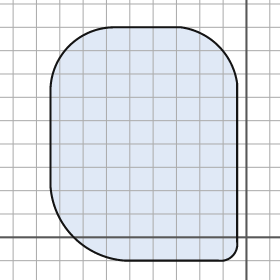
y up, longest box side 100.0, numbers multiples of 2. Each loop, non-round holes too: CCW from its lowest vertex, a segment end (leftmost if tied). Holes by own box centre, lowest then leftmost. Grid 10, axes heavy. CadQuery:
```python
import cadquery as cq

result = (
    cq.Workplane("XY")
    .moveTo(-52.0, -10.0)
    .lineTo(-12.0, -10.0)
    .threePointArc((-6.0, -8.0), (-4.0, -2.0))
    .lineTo(-4.0, 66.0)
    .threePointArc((-12.0, 82.0), (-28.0, 90.0))
    .lineTo(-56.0, 90.0)
    .threePointArc((-76.0, 82.0), (-84.0, 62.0))
    .lineTo(-84.0, 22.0)
    .threePointArc((-74.0, 0.0), (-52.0, -10.0))
    .close()
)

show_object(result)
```